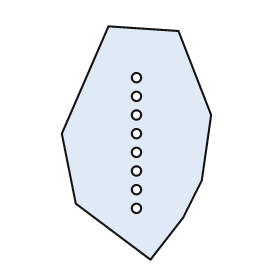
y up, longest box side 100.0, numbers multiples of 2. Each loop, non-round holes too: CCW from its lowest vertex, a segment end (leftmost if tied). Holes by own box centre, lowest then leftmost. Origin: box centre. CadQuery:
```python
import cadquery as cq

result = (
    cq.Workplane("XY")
    .moveTo(6.0, -50.0)
    .lineTo(20.0, -32.0)
    .lineTo(28.0, -16.0)
    .lineTo(32.0, 12.0)
    .lineTo(18.0, 48.0)
    .lineTo(-12.0, 50.0)
    .lineTo(-32.0, 4.0)
    .lineTo(-26.0, -26.0)
    .close()
    .moveTo(0.0, -28.0)
    .circle(2.0)
    .moveTo(0.0, -20.0)
    .circle(2.0)
    .moveTo(0.0, -12.0)
    .circle(2.0)
    .moveTo(0.0, -4.0)
    .circle(2.0)
    .moveTo(0.0, 4.0)
    .circle(2.0)
    .moveTo(0.0, 12.0)
    .circle(2.0)
    .moveTo(0.0, 20.0)
    .circle(2.0)
    .moveTo(0.0, 28.0)
    .circle(2.0)
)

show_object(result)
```